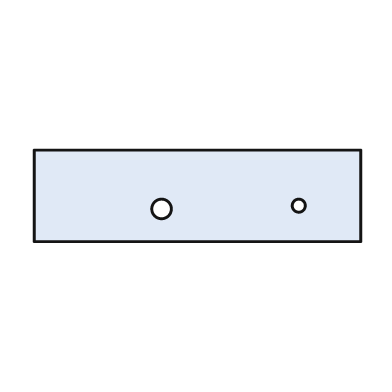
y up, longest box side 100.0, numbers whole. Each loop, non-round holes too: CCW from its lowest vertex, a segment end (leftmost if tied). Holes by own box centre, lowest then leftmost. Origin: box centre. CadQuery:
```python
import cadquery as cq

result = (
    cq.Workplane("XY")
    .moveTo(-50.0, -14.0)
    .lineTo(50.0, -14.0)
    .lineTo(50.0, 14.0)
    .lineTo(-50.0, 14.0)
    .close()
    .moveTo(-11.0, -4.0)
    .circle(3.0)
    .moveTo(31.0, -3.0)
    .circle(2.0)
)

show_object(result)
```